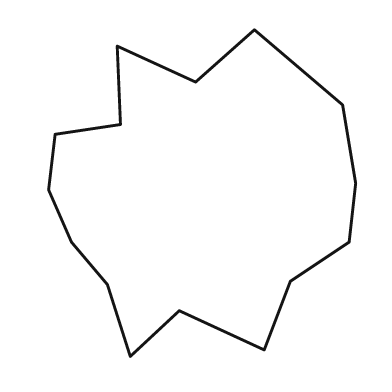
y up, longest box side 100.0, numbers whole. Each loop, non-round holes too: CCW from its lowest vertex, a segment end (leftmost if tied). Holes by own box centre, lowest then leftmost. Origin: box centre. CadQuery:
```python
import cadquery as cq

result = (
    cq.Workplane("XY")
    .moveTo(-22.0, -50.0)
    .lineTo(-7.0, -36.0)
    .lineTo(19.0, -48.0)
    .lineTo(27.0, -27.0)
    .lineTo(45.0, -15.0)
    .lineTo(47.0, 3.0)
    .lineTo(43.0, 27.0)
    .lineTo(16.0, 50.0)
    .lineTo(-2.0, 34.0)
    .lineTo(-26.0, 45.0)
    .lineTo(-25.0, 21.0)
    .lineTo(-45.0, 18.0)
    .lineTo(-47.0, 1.0)
    .lineTo(-40.0, -15.0)
    .lineTo(-29.0, -28.0)
    .close()
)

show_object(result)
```